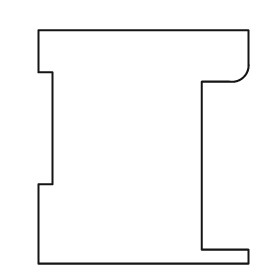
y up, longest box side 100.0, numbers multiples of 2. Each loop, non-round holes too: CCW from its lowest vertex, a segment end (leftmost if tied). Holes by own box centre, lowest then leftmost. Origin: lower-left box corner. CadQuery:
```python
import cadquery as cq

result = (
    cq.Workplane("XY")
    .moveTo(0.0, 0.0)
    .lineTo(90.0, 0.0)
    .lineTo(90.0, 6.0)
    .lineTo(70.0, 6.0)
    .lineTo(70.0, 78.0)
    .lineTo(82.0, 78.0)
    .threePointArc((88.0, 80.0), (90.0, 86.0))
    .lineTo(90.0, 100.0)
    .lineTo(0.0, 100.0)
    .lineTo(0.0, 82.0)
    .lineTo(6.0, 82.0)
    .lineTo(6.0, 34.0)
    .lineTo(0.0, 34.0)
    .close()
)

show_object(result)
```